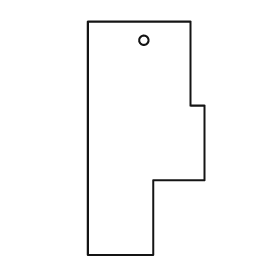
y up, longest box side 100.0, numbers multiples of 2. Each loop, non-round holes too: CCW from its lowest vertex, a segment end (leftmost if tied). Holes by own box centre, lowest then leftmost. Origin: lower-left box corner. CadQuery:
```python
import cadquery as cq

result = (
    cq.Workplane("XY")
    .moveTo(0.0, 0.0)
    .lineTo(28.0, 0.0)
    .lineTo(28.0, 32.0)
    .lineTo(50.0, 32.0)
    .lineTo(50.0, 64.0)
    .lineTo(44.0, 64.0)
    .lineTo(44.0, 100.0)
    .lineTo(0.0, 100.0)
    .close()
    .moveTo(24.0, 92.0)
    .circle(2.0)
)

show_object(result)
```